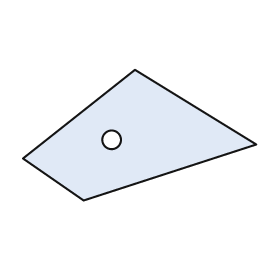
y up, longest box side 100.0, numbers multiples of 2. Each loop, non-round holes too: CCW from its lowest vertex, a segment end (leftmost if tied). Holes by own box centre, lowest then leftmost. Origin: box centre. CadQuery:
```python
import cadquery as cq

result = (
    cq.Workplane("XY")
    .moveTo(-24.0, -28.0)
    .lineTo(50.0, -4.0)
    .lineTo(-2.0, 28.0)
    .lineTo(-50.0, -10.0)
    .close()
    .moveTo(-12.0, -2.0)
    .circle(4.0)
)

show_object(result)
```